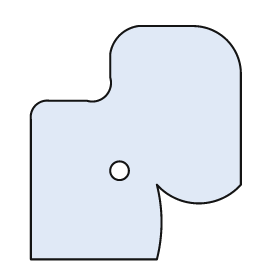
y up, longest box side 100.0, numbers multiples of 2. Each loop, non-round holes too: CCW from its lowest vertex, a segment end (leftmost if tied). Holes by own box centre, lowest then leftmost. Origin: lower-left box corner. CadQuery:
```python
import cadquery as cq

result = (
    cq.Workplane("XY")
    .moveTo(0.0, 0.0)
    .lineTo(54.0, 0.0)
    .threePointArc((56.0, 16.0), (54.0, 32.0))
    .threePointArc((72.0, 24.0), (90.0, 32.0))
    .lineTo(90.0, 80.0)
    .threePointArc((84.0, 94.0), (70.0, 100.0))
    .lineTo(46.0, 100.0)
    .threePointArc((38.0, 96.0), (34.0, 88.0))
    .lineTo(34.0, 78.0)
    .threePointArc((32.0, 70.0), (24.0, 68.0))
    .lineTo(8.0, 68.0)
    .threePointArc((2.0, 66.0), (0.0, 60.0))
    .close()
    .moveTo(38.0, 38.0)
    .circle(4.0)
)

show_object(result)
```